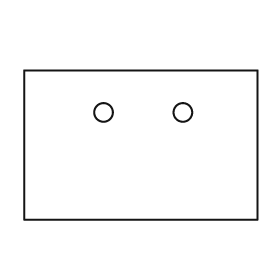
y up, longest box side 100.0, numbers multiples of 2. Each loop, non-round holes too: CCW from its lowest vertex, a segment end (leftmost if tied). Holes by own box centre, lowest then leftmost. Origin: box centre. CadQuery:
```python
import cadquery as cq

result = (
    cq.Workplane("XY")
    .moveTo(-50.0, -32.0)
    .lineTo(50.0, -32.0)
    .lineTo(50.0, 32.0)
    .lineTo(-50.0, 32.0)
    .close()
    .moveTo(-16.0, 14.0)
    .circle(4.0)
    .moveTo(18.0, 14.0)
    .circle(4.0)
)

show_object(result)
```